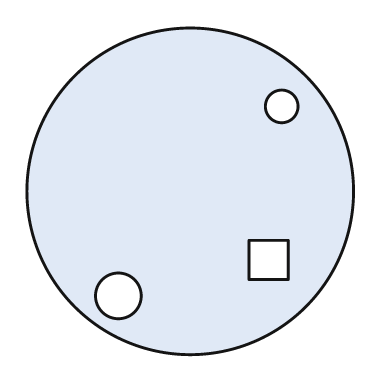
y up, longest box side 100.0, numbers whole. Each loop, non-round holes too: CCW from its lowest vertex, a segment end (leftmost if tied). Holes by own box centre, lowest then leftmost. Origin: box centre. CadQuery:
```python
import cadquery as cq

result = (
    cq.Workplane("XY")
    .moveTo(0.0, 0.0)
    .circle(50.0)
    .moveTo(-22.0, -32.0)
    .circle(7.0)
    .moveTo(18.0, -27.0)
    .lineTo(30.0, -27.0)
    .lineTo(30.0, -15.0)
    .lineTo(18.0, -15.0)
    .close()
    .moveTo(28.0, 26.0)
    .circle(5.0)
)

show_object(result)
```